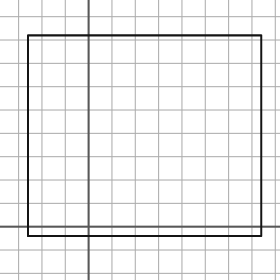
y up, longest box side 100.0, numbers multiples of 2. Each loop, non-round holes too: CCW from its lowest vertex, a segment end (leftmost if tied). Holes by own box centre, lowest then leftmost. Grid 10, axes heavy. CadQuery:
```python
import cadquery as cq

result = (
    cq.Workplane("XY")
    .moveTo(-26.0, -4.0)
    .lineTo(74.0, -4.0)
    .lineTo(74.0, 82.0)
    .lineTo(-26.0, 82.0)
    .close()
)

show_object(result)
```